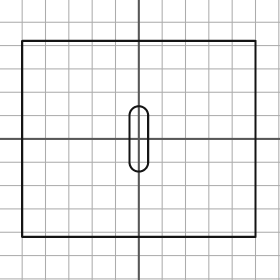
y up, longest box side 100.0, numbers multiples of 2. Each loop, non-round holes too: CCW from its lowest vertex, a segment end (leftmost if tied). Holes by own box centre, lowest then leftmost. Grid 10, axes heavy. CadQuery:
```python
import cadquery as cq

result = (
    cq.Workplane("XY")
    .moveTo(-50.0, -42.0)
    .lineTo(50.0, -42.0)
    .lineTo(50.0, 42.0)
    .lineTo(-50.0, 42.0)
    .close()
    .moveTo(-4.0, -10.0)
    .threePointArc((0.0, -14.0), (4.0, -10.0))
    .lineTo(4.0, 10.0)
    .threePointArc((0.0, 14.0), (-4.0, 10.0))
    .close()
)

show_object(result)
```